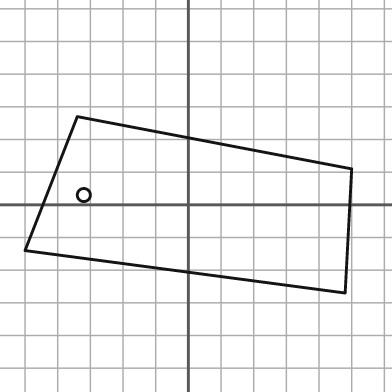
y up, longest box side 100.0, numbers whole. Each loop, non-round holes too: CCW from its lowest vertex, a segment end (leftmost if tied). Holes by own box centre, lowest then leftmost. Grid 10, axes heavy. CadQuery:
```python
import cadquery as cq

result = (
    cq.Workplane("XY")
    .moveTo(48.0, -27.0)
    .lineTo(50.0, 11.0)
    .lineTo(-34.0, 27.0)
    .lineTo(-50.0, -14.0)
    .close()
    .moveTo(-32.0, 3.0)
    .circle(2.0)
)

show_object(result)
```